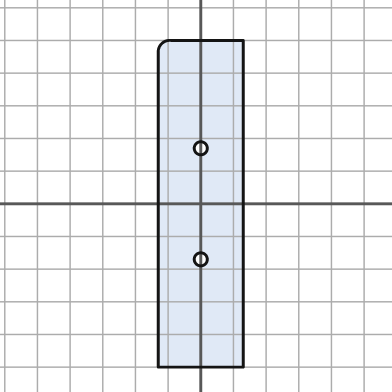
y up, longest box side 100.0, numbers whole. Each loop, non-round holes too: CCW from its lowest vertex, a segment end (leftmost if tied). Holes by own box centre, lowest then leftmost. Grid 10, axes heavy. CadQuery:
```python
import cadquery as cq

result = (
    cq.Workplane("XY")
    .moveTo(-13.0, -50.0)
    .lineTo(13.0, -50.0)
    .lineTo(13.0, 50.0)
    .lineTo(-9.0, 50.0)
    .threePointArc((-12.0, 49.0), (-13.0, 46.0))
    .close()
    .moveTo(0.0, -17.0)
    .circle(2.0)
    .moveTo(0.0, 17.0)
    .circle(2.0)
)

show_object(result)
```